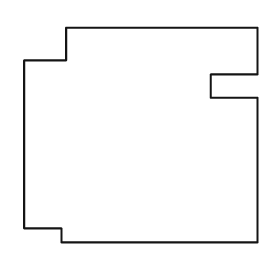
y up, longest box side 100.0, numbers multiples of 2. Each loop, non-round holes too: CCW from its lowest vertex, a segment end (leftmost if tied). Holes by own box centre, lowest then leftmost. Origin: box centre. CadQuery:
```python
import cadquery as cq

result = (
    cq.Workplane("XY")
    .moveTo(-34.0, -46.0)
    .lineTo(50.0, -46.0)
    .lineTo(50.0, 16.0)
    .lineTo(30.0, 16.0)
    .lineTo(30.0, 26.0)
    .lineTo(50.0, 26.0)
    .lineTo(50.0, 46.0)
    .lineTo(-32.0, 46.0)
    .lineTo(-32.0, 32.0)
    .lineTo(-50.0, 32.0)
    .lineTo(-50.0, -40.0)
    .lineTo(-34.0, -40.0)
    .close()
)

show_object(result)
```